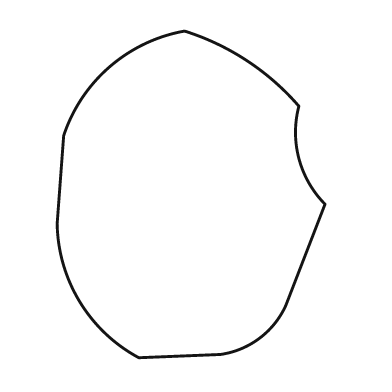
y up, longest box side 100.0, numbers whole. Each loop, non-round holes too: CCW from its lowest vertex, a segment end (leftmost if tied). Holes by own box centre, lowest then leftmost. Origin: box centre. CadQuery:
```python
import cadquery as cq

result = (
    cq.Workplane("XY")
    .moveTo(-16.0, -50.0)
    .lineTo(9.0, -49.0)
    .threePointArc((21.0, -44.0), (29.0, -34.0))
    .lineTo(41.0, -3.0)
    .threePointArc((33.0, 11.0), (33.0, 27.0))
    .threePointArc((17.0, 41.0), (-2.0, 50.0))
    .threePointArc((-25.0, 39.0), (-39.0, 18.0))
    .lineTo(-41.0, -9.0)
    .threePointArc((-34.0, -33.0), (-16.0, -50.0))
    .close()
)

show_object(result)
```